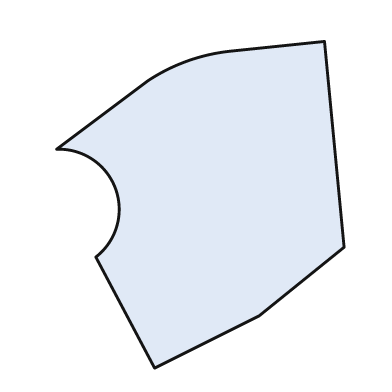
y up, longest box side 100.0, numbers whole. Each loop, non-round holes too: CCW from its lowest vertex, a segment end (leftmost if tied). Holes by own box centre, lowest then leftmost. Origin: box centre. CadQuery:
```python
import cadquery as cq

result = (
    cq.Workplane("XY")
    .moveTo(-14.0, -50.0)
    .lineTo(18.0, -34.0)
    .lineTo(44.0, -13.0)
    .lineTo(38.0, 50.0)
    .lineTo(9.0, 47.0)
    .threePointArc((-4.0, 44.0), (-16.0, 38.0))
    .lineTo(-44.0, 17.0)
    .threePointArc((-26.0, 5.0), (-32.0, -16.0))
    .close()
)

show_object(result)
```